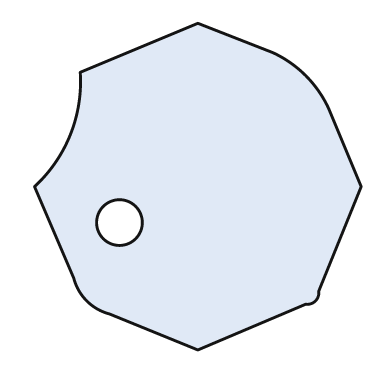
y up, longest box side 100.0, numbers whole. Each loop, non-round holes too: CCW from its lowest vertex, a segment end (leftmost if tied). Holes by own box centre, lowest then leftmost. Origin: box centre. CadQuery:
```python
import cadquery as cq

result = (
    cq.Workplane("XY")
    .moveTo(0.0, -50.0)
    .lineTo(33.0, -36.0)
    .threePointArc((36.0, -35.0), (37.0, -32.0))
    .lineTo(50.0, 0.0)
    .lineTo(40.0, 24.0)
    .threePointArc((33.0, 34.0), (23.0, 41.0))
    .lineTo(0.0, 50.0)
    .lineTo(-36.0, 35.0)
    .threePointArc((-39.0, 16.0), (-50.0, 0.0))
    .lineTo(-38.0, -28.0)
    .threePointArc((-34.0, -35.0), (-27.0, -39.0))
    .close()
    .moveTo(-24.0, -11.0)
    .circle(7.0)
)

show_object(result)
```